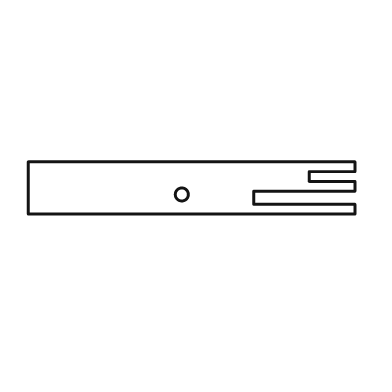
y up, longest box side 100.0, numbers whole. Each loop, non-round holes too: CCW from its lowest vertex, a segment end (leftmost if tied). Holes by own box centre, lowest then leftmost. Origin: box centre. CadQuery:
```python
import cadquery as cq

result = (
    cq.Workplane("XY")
    .moveTo(-50.0, -8.0)
    .lineTo(50.0, -8.0)
    .lineTo(50.0, -5.0)
    .lineTo(19.0, -5.0)
    .lineTo(19.0, -1.0)
    .lineTo(50.0, -1.0)
    .lineTo(50.0, 2.0)
    .lineTo(36.0, 2.0)
    .lineTo(36.0, 5.0)
    .lineTo(50.0, 5.0)
    .lineTo(50.0, 8.0)
    .lineTo(-50.0, 8.0)
    .close()
    .moveTo(-3.0, -2.0)
    .circle(2.0)
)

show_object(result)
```